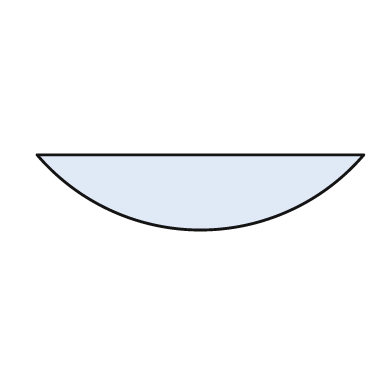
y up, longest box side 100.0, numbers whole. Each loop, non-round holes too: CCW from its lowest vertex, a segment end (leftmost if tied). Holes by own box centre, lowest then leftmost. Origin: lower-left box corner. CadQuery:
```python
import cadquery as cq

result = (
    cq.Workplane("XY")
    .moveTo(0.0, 23.0)
    .threePointArc((50.0, 0.0), (100.0, 23.0))
    .close()
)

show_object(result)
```